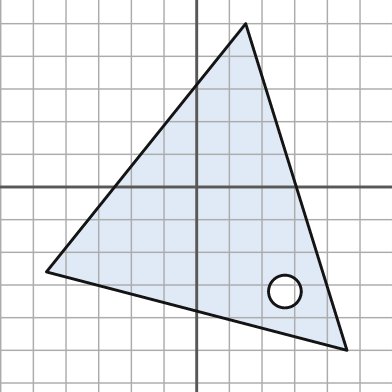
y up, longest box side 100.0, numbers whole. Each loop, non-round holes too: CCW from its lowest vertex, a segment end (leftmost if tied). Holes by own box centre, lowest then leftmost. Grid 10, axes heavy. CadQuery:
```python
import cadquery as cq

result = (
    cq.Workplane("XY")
    .moveTo(46.0, -50.0)
    .lineTo(15.0, 50.0)
    .lineTo(-46.0, -26.0)
    .close()
    .moveTo(27.0, -32.0)
    .circle(5.0)
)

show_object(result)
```